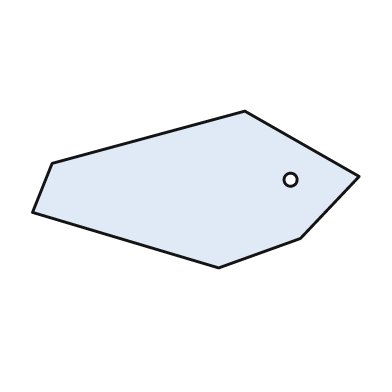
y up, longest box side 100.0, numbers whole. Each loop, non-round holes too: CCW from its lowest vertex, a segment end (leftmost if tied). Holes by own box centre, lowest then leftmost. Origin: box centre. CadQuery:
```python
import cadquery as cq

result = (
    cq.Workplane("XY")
    .moveTo(7.0, -24.0)
    .lineTo(32.0, -15.0)
    .lineTo(50.0, 4.0)
    .lineTo(15.0, 24.0)
    .lineTo(-44.0, 8.0)
    .lineTo(-50.0, -7.0)
    .close()
    .moveTo(29.0, 3.0)
    .circle(2.0)
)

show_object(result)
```